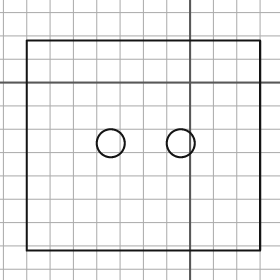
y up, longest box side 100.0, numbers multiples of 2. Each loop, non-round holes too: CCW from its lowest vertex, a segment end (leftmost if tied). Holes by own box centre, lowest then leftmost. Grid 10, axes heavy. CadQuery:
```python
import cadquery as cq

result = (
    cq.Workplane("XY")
    .moveTo(-70.0, -72.0)
    .lineTo(30.0, -72.0)
    .lineTo(30.0, 18.0)
    .lineTo(-70.0, 18.0)
    .close()
    .moveTo(-34.0, -26.0)
    .circle(6.0)
    .moveTo(-4.0, -26.0)
    .circle(6.0)
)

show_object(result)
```